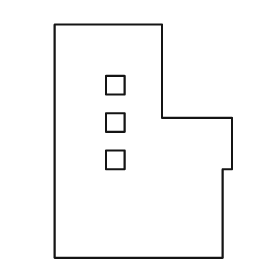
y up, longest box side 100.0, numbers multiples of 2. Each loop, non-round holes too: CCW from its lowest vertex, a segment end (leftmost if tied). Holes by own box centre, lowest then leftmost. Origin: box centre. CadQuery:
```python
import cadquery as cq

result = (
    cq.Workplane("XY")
    .moveTo(-38.0, -50.0)
    .lineTo(34.0, -50.0)
    .lineTo(34.0, -12.0)
    .lineTo(38.0, -12.0)
    .lineTo(38.0, 10.0)
    .lineTo(8.0, 10.0)
    .lineTo(8.0, 50.0)
    .lineTo(-38.0, 50.0)
    .close()
    .moveTo(-16.0, -12.0)
    .lineTo(-8.0, -12.0)
    .lineTo(-8.0, -4.0)
    .lineTo(-16.0, -4.0)
    .close()
    .moveTo(-16.0, 4.0)
    .lineTo(-8.0, 4.0)
    .lineTo(-8.0, 12.0)
    .lineTo(-16.0, 12.0)
    .close()
    .moveTo(-16.0, 20.0)
    .lineTo(-8.0, 20.0)
    .lineTo(-8.0, 28.0)
    .lineTo(-16.0, 28.0)
    .close()
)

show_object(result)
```